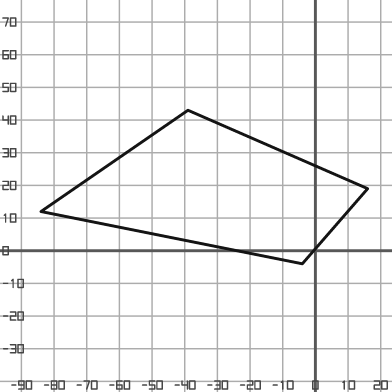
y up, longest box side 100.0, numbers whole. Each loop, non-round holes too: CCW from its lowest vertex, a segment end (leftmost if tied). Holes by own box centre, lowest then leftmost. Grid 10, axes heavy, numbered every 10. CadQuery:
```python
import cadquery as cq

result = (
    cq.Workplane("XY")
    .moveTo(-4.0, -4.0)
    .lineTo(16.0, 19.0)
    .lineTo(-39.0, 43.0)
    .lineTo(-84.0, 12.0)
    .close()
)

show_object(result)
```